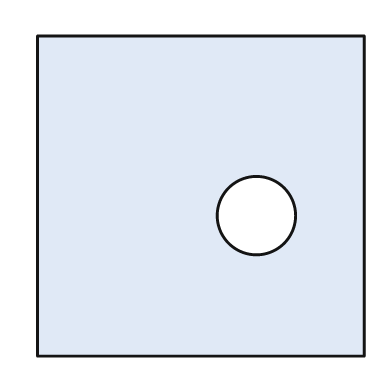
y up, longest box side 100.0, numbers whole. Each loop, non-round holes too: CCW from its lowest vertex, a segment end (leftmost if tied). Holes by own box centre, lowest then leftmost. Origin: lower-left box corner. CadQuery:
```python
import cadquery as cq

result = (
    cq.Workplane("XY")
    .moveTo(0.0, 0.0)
    .lineTo(100.0, 0.0)
    .lineTo(100.0, 98.0)
    .lineTo(0.0, 98.0)
    .close()
    .moveTo(67.0, 43.0)
    .circle(12.0)
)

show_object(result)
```